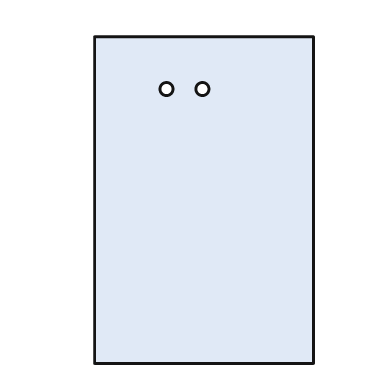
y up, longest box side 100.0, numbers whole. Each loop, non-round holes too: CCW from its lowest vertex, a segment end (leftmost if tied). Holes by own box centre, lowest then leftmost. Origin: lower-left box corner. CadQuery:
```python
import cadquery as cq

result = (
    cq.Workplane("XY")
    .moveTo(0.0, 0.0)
    .lineTo(67.0, 0.0)
    .lineTo(67.0, 100.0)
    .lineTo(0.0, 100.0)
    .close()
    .moveTo(22.0, 84.0)
    .circle(2.0)
    .moveTo(33.0, 84.0)
    .circle(2.0)
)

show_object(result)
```